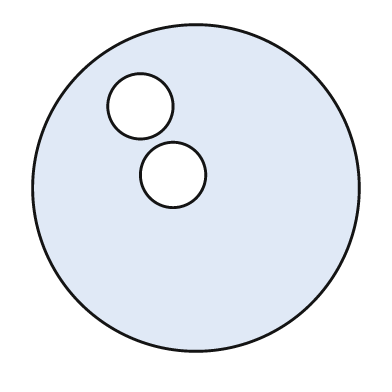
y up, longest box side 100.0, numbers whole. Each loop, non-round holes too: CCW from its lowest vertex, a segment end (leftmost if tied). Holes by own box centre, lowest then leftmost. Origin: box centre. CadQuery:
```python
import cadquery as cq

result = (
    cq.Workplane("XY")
    .moveTo(0.0, 0.0)
    .circle(50.0)
    .moveTo(-7.0, 4.0)
    .circle(10.0)
    .moveTo(-17.0, 25.0)
    .circle(10.0)
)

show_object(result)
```